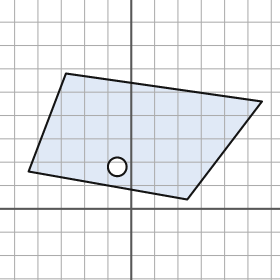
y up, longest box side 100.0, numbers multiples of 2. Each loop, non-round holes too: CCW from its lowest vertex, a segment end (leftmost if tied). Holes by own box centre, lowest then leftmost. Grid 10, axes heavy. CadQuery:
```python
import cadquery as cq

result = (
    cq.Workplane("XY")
    .moveTo(24.0, 4.0)
    .lineTo(56.0, 46.0)
    .lineTo(-28.0, 58.0)
    .lineTo(-44.0, 16.0)
    .close()
    .moveTo(-6.0, 18.0)
    .circle(4.0)
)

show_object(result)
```